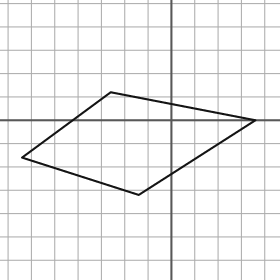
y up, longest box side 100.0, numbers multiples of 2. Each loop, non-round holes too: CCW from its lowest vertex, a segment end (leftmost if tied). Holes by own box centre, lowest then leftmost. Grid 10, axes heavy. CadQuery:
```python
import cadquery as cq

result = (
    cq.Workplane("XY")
    .moveTo(-14.0, -32.0)
    .lineTo(36.0, 0.0)
    .lineTo(-26.0, 12.0)
    .lineTo(-64.0, -16.0)
    .close()
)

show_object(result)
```